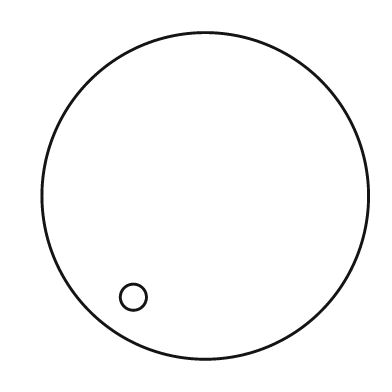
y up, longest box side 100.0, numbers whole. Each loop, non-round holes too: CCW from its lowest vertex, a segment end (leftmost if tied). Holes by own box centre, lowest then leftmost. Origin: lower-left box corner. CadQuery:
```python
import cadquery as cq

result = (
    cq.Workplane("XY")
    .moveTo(50.0, 50.0)
    .circle(50.0)
    .moveTo(28.0, 19.0)
    .circle(4.0)
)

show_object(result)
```